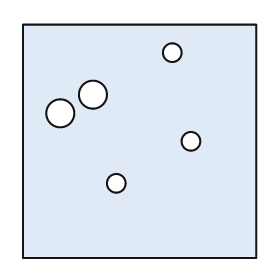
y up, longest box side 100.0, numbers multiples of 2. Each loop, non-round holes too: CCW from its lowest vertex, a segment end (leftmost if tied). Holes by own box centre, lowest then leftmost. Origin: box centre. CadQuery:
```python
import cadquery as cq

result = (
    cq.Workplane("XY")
    .moveTo(-50.0, -50.0)
    .lineTo(50.0, -50.0)
    .lineTo(50.0, 50.0)
    .lineTo(-50.0, 50.0)
    .close()
    .moveTo(-10.0, -18.0)
    .circle(4.0)
    .moveTo(22.0, 0.0)
    .circle(4.0)
    .moveTo(-34.0, 12.0)
    .circle(6.0)
    .moveTo(-20.0, 20.0)
    .circle(6.0)
    .moveTo(14.0, 38.0)
    .circle(4.0)
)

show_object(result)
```